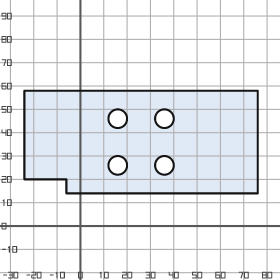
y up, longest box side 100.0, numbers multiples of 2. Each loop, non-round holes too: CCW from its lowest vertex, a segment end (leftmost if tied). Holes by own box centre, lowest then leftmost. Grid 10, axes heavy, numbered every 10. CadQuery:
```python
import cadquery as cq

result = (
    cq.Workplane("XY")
    .moveTo(-6.0, 14.0)
    .lineTo(76.0, 14.0)
    .lineTo(76.0, 58.0)
    .lineTo(-24.0, 58.0)
    .lineTo(-24.0, 20.0)
    .lineTo(-6.0, 20.0)
    .close()
    .moveTo(16.0, 26.0)
    .circle(4.0)
    .moveTo(36.0, 26.0)
    .circle(4.0)
    .moveTo(16.0, 46.0)
    .circle(4.0)
    .moveTo(36.0, 46.0)
    .circle(4.0)
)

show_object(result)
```